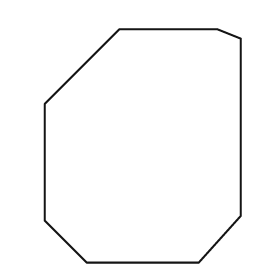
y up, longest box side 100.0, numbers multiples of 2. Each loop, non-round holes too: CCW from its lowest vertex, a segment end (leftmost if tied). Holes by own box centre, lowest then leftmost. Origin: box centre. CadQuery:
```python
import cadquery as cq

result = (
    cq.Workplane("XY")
    .moveTo(-24.0, -50.0)
    .lineTo(24.0, -50.0)
    .lineTo(42.0, -30.0)
    .lineTo(42.0, 46.0)
    .lineTo(32.0, 50.0)
    .lineTo(-10.0, 50.0)
    .lineTo(-42.0, 18.0)
    .lineTo(-42.0, -32.0)
    .close()
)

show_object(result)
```